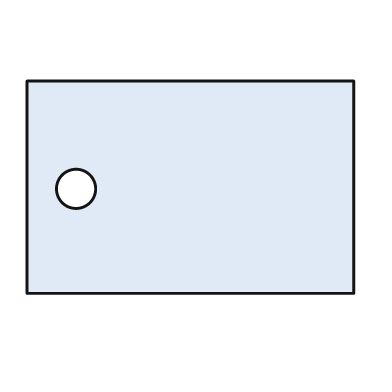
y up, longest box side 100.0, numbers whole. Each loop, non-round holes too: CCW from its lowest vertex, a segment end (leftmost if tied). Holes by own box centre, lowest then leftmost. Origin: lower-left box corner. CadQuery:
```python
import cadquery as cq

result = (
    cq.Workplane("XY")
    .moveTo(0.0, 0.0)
    .lineTo(100.0, 0.0)
    .lineTo(100.0, 65.0)
    .lineTo(0.0, 65.0)
    .close()
    .moveTo(15.0, 32.0)
    .circle(6.0)
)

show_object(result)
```